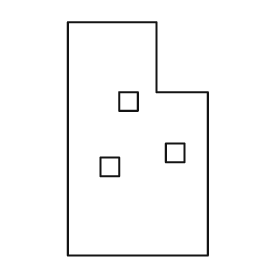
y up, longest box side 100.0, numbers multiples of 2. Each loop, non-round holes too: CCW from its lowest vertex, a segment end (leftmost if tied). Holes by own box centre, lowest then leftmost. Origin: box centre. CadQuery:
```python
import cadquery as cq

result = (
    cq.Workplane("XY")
    .moveTo(-30.0, -50.0)
    .lineTo(30.0, -50.0)
    .lineTo(30.0, 20.0)
    .lineTo(8.0, 20.0)
    .lineTo(8.0, 50.0)
    .lineTo(-30.0, 50.0)
    .close()
    .moveTo(-16.0, -16.0)
    .lineTo(-8.0, -16.0)
    .lineTo(-8.0, -8.0)
    .lineTo(-16.0, -8.0)
    .close()
    .moveTo(12.0, -10.0)
    .lineTo(20.0, -10.0)
    .lineTo(20.0, -2.0)
    .lineTo(12.0, -2.0)
    .close()
    .moveTo(-8.0, 12.0)
    .lineTo(0.0, 12.0)
    .lineTo(0.0, 20.0)
    .lineTo(-8.0, 20.0)
    .close()
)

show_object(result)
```